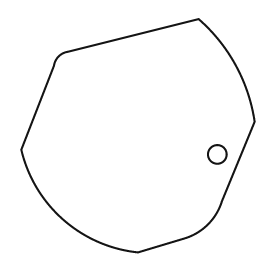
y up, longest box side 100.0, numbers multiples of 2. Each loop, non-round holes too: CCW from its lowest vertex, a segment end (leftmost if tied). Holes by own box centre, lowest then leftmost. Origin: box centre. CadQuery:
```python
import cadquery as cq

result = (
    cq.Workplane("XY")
    .moveTo(0.0, -50.0)
    .lineTo(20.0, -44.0)
    .threePointArc((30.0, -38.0), (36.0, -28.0))
    .lineTo(50.0, 6.0)
    .threePointArc((42.0, 30.0), (26.0, 50.0))
    .lineTo(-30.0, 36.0)
    .threePointArc((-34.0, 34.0), (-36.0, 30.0))
    .lineTo(-50.0, -6.0)
    .threePointArc((-32.0, -36.0), (0.0, -50.0))
    .close()
    .moveTo(34.0, -8.0)
    .circle(4.0)
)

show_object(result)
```